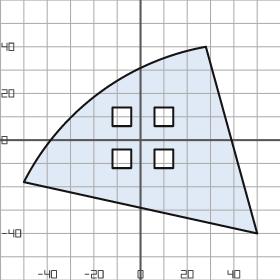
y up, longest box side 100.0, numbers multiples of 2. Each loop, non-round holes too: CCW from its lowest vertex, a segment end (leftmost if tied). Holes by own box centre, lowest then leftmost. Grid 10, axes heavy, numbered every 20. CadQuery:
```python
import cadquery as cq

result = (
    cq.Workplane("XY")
    .moveTo(50.0, -40.0)
    .lineTo(28.0, 40.0)
    .threePointArc((-18.0, 20.0), (-50.0, -18.0))
    .close()
    .moveTo(-12.0, -12.0)
    .lineTo(-4.0, -12.0)
    .lineTo(-4.0, -4.0)
    .lineTo(-12.0, -4.0)
    .close()
    .moveTo(6.0, -12.0)
    .lineTo(14.0, -12.0)
    .lineTo(14.0, -4.0)
    .lineTo(6.0, -4.0)
    .close()
    .moveTo(-12.0, 6.0)
    .lineTo(-4.0, 6.0)
    .lineTo(-4.0, 14.0)
    .lineTo(-12.0, 14.0)
    .close()
    .moveTo(6.0, 6.0)
    .lineTo(14.0, 6.0)
    .lineTo(14.0, 14.0)
    .lineTo(6.0, 14.0)
    .close()
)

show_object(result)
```